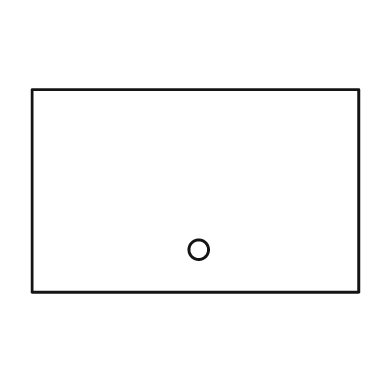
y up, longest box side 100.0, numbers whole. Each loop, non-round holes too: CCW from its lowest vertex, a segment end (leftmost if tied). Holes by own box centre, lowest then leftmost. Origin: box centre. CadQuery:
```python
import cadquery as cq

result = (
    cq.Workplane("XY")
    .moveTo(-50.0, -31.0)
    .lineTo(50.0, -31.0)
    .lineTo(50.0, 31.0)
    .lineTo(-50.0, 31.0)
    .close()
    .moveTo(1.0, -18.0)
    .circle(3.0)
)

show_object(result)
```